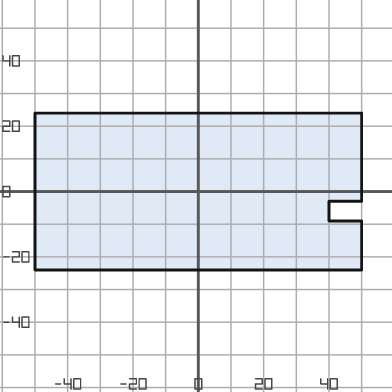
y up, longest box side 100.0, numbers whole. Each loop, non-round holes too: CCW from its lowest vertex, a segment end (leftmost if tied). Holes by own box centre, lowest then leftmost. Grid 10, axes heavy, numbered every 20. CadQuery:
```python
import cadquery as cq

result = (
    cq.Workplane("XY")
    .moveTo(-50.0, -24.0)
    .lineTo(50.0, -24.0)
    .lineTo(50.0, -9.0)
    .lineTo(40.0, -9.0)
    .lineTo(40.0, -3.0)
    .lineTo(50.0, -3.0)
    .lineTo(50.0, 24.0)
    .lineTo(-50.0, 24.0)
    .close()
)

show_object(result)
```